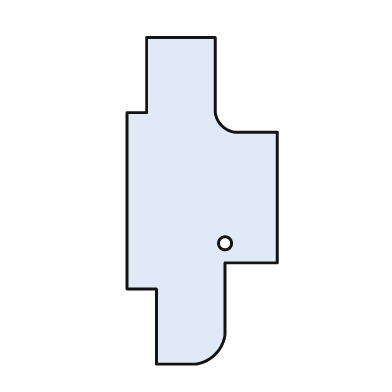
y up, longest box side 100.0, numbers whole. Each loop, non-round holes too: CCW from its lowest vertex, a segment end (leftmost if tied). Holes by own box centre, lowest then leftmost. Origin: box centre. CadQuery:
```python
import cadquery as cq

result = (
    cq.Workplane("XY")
    .moveTo(-14.0, -50.0)
    .lineTo(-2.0, -50.0)
    .threePointArc((4.0, -47.0), (7.0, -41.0))
    .lineTo(7.0, -19.0)
    .lineTo(23.0, -19.0)
    .lineTo(23.0, 21.0)
    .lineTo(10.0, 21.0)
    .threePointArc((6.0, 23.0), (4.0, 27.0))
    .lineTo(4.0, 50.0)
    .lineTo(-17.0, 50.0)
    .lineTo(-17.0, 27.0)
    .lineTo(-23.0, 27.0)
    .lineTo(-23.0, -27.0)
    .lineTo(-14.0, -27.0)
    .close()
    .moveTo(7.0, -13.0)
    .circle(2.0)
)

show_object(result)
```